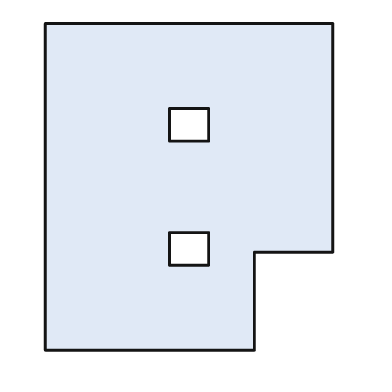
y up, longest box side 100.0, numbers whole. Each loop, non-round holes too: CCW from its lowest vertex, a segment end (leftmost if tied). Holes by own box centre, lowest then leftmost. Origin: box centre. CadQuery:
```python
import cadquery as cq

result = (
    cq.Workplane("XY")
    .moveTo(-44.0, -50.0)
    .lineTo(20.0, -50.0)
    .lineTo(20.0, -20.0)
    .lineTo(44.0, -20.0)
    .lineTo(44.0, 50.0)
    .lineTo(-44.0, 50.0)
    .close()
    .moveTo(-6.0, -24.0)
    .lineTo(6.0, -24.0)
    .lineTo(6.0, -14.0)
    .lineTo(-6.0, -14.0)
    .close()
    .moveTo(-6.0, 14.0)
    .lineTo(6.0, 14.0)
    .lineTo(6.0, 24.0)
    .lineTo(-6.0, 24.0)
    .close()
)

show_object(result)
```